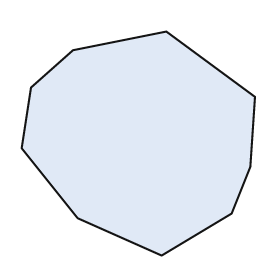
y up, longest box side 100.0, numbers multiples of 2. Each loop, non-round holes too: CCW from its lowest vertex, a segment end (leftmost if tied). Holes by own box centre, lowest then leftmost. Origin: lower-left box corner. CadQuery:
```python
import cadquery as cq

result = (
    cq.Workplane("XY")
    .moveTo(60.0, 0.0)
    .lineTo(90.0, 18.0)
    .lineTo(98.0, 38.0)
    .lineTo(100.0, 68.0)
    .lineTo(62.0, 96.0)
    .lineTo(22.0, 88.0)
    .lineTo(4.0, 72.0)
    .lineTo(0.0, 46.0)
    .lineTo(24.0, 16.0)
    .close()
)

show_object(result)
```